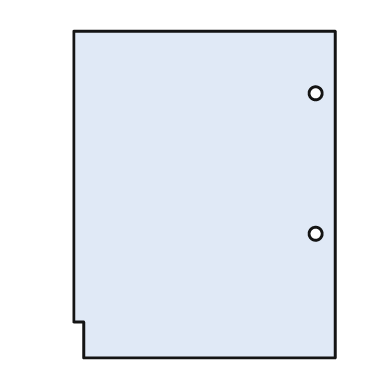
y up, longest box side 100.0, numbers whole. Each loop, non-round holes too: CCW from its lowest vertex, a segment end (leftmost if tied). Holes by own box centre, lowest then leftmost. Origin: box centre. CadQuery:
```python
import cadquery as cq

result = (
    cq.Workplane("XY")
    .moveTo(-37.0, -50.0)
    .lineTo(40.0, -50.0)
    .lineTo(40.0, 50.0)
    .lineTo(-40.0, 50.0)
    .lineTo(-40.0, -39.0)
    .lineTo(-37.0, -39.0)
    .close()
    .moveTo(34.0, -12.0)
    .circle(2.0)
    .moveTo(34.0, 31.0)
    .circle(2.0)
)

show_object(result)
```